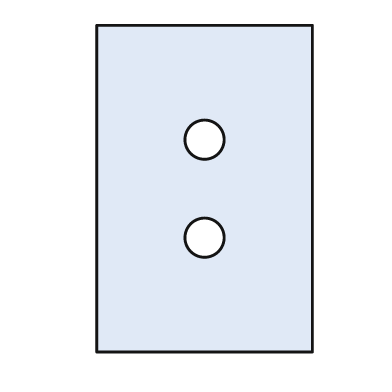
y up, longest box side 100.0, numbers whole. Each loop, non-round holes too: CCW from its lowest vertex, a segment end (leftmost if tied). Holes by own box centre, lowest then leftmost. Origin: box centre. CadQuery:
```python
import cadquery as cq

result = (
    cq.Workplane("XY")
    .moveTo(-33.0, -50.0)
    .lineTo(33.0, -50.0)
    .lineTo(33.0, 50.0)
    .lineTo(-33.0, 50.0)
    .close()
    .moveTo(0.0, -15.0)
    .circle(6.0)
    .moveTo(0.0, 15.0)
    .circle(6.0)
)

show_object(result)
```